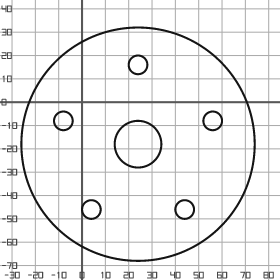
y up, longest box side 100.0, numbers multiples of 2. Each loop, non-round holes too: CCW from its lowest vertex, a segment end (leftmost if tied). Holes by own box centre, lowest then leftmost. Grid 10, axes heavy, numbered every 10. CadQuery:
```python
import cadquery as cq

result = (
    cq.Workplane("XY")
    .moveTo(24.0, -18.0)
    .circle(50.0)
    .moveTo(4.0, -46.0)
    .circle(4.0)
    .moveTo(44.0, -46.0)
    .circle(4.0)
    .moveTo(24.0, -18.0)
    .circle(10.0)
    .moveTo(-8.0, -8.0)
    .circle(4.0)
    .moveTo(56.0, -8.0)
    .circle(4.0)
    .moveTo(24.0, 16.0)
    .circle(4.0)
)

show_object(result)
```